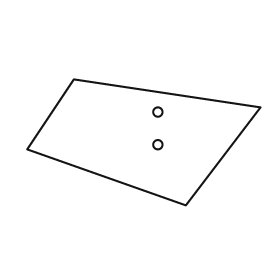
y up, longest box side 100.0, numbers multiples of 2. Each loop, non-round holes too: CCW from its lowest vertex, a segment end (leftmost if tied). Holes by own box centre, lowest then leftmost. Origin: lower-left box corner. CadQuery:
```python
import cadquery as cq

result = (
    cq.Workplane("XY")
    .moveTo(68.0, 0.0)
    .lineTo(100.0, 42.0)
    .lineTo(20.0, 54.0)
    .lineTo(0.0, 24.0)
    .close()
    .moveTo(56.0, 26.0)
    .circle(2.0)
    .moveTo(56.0, 40.0)
    .circle(2.0)
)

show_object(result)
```